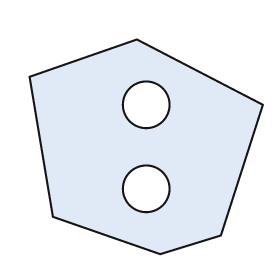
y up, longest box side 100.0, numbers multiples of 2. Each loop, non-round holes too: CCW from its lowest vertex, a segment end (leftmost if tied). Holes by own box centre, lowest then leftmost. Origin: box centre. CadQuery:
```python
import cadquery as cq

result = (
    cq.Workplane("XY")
    .moveTo(6.0, -46.0)
    .lineTo(32.0, -38.0)
    .lineTo(50.0, 18.0)
    .lineTo(-4.0, 46.0)
    .lineTo(-50.0, 30.0)
    .lineTo(-40.0, -30.0)
    .close()
    .moveTo(0.0, -18.0)
    .circle(10.0)
    .moveTo(0.0, 18.0)
    .circle(10.0)
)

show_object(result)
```